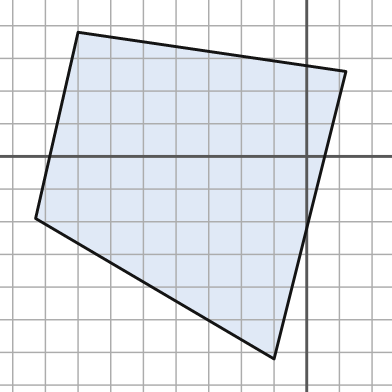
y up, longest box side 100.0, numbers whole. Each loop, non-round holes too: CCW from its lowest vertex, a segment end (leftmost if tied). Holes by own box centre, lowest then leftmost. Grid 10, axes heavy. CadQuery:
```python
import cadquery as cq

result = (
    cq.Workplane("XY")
    .moveTo(-10.0, -62.0)
    .lineTo(12.0, 26.0)
    .lineTo(-70.0, 38.0)
    .lineTo(-83.0, -19.0)
    .close()
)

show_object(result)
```